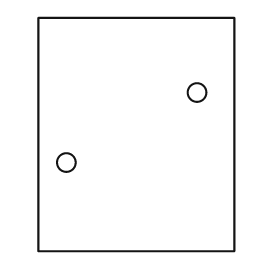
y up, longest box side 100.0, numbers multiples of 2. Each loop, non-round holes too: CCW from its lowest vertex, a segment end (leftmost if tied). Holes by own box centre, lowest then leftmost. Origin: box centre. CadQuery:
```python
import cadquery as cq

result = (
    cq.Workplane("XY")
    .moveTo(-42.0, -50.0)
    .lineTo(42.0, -50.0)
    .lineTo(42.0, 50.0)
    .lineTo(-42.0, 50.0)
    .close()
    .moveTo(-30.0, -12.0)
    .circle(4.0)
    .moveTo(26.0, 18.0)
    .circle(4.0)
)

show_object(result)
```